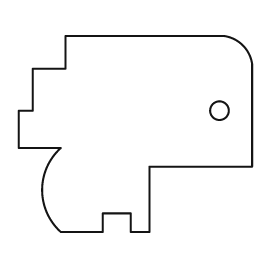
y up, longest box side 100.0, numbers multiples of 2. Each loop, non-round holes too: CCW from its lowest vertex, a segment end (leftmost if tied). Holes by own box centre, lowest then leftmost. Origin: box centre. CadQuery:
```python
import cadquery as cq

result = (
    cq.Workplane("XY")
    .moveTo(-32.0, -42.0)
    .lineTo(-14.0, -42.0)
    .lineTo(-14.0, -34.0)
    .lineTo(-2.0, -34.0)
    .lineTo(-2.0, -42.0)
    .lineTo(6.0, -42.0)
    .lineTo(6.0, -14.0)
    .lineTo(50.0, -14.0)
    .lineTo(50.0, 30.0)
    .threePointArc((46.0, 38.0), (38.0, 42.0))
    .lineTo(-30.0, 42.0)
    .lineTo(-30.0, 28.0)
    .lineTo(-44.0, 28.0)
    .lineTo(-44.0, 10.0)
    .lineTo(-50.0, 10.0)
    .lineTo(-50.0, -6.0)
    .lineTo(-32.0, -6.0)
    .threePointArc((-40.0, -24.0), (-32.0, -42.0))
    .close()
    .moveTo(36.0, 10.0)
    .circle(4.0)
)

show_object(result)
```